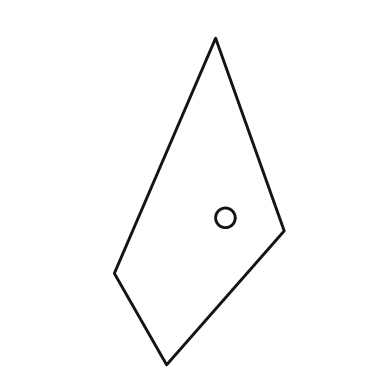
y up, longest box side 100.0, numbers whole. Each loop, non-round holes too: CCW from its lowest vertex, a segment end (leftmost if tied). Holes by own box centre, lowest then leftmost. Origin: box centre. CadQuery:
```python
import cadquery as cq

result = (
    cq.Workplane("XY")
    .moveTo(-10.0, -50.0)
    .lineTo(26.0, -9.0)
    .lineTo(5.0, 50.0)
    .lineTo(-26.0, -22.0)
    .close()
    .moveTo(8.0, -5.0)
    .circle(3.0)
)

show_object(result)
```